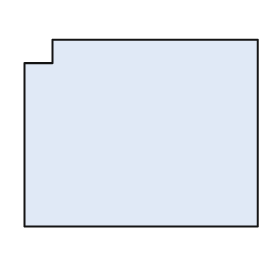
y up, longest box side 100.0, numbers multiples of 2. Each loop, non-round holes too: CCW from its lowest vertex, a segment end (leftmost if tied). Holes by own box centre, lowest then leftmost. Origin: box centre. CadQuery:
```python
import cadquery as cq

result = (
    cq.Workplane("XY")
    .moveTo(-50.0, -40.0)
    .lineTo(50.0, -40.0)
    .lineTo(50.0, 40.0)
    .lineTo(-38.0, 40.0)
    .lineTo(-38.0, 30.0)
    .lineTo(-50.0, 30.0)
    .close()
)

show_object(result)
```